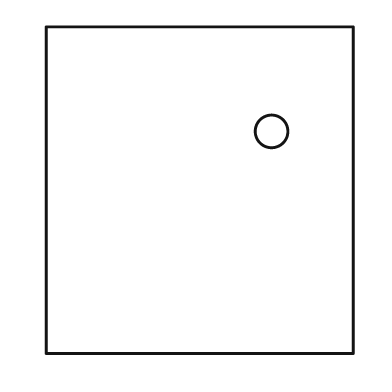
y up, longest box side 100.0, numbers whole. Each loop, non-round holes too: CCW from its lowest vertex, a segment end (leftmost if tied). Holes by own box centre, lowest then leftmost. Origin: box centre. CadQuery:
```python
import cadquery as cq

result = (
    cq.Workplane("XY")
    .moveTo(-47.0, -50.0)
    .lineTo(47.0, -50.0)
    .lineTo(47.0, 50.0)
    .lineTo(-47.0, 50.0)
    .close()
    .moveTo(22.0, 18.0)
    .circle(5.0)
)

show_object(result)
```